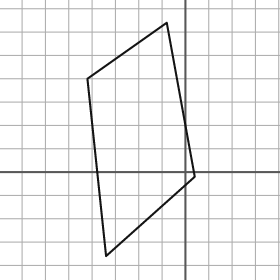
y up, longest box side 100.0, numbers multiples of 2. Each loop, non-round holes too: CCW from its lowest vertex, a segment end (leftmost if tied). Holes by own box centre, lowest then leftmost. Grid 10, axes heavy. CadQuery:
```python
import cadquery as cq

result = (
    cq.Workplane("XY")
    .moveTo(-34.0, -36.0)
    .lineTo(4.0, -2.0)
    .lineTo(-8.0, 64.0)
    .lineTo(-42.0, 40.0)
    .close()
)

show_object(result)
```